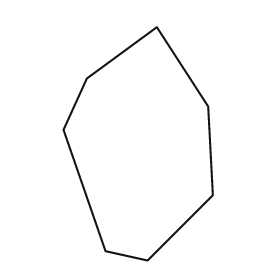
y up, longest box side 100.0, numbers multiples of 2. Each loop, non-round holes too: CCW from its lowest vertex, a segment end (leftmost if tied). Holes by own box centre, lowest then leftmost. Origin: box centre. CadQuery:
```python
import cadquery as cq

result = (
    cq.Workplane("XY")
    .moveTo(4.0, -50.0)
    .lineTo(32.0, -22.0)
    .lineTo(30.0, 16.0)
    .lineTo(8.0, 50.0)
    .lineTo(-22.0, 28.0)
    .lineTo(-32.0, 6.0)
    .lineTo(-14.0, -46.0)
    .close()
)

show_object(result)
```